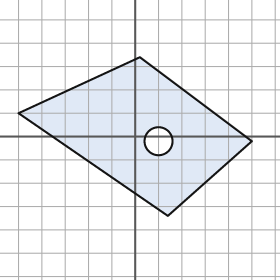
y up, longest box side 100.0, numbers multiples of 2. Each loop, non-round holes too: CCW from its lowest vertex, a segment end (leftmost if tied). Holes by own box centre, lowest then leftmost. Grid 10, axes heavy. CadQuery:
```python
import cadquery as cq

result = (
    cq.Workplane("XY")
    .moveTo(14.0, -34.0)
    .lineTo(50.0, -2.0)
    .lineTo(2.0, 34.0)
    .lineTo(-50.0, 10.0)
    .close()
    .moveTo(10.0, -2.0)
    .circle(6.0)
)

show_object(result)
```